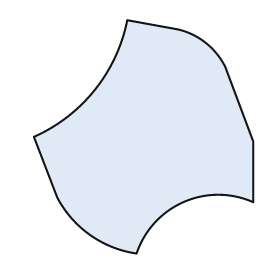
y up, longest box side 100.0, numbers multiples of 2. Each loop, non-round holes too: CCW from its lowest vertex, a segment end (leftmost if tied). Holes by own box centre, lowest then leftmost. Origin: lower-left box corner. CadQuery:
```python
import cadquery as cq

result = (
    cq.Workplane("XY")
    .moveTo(44.0, 0.0)
    .threePointArc((64.0, 22.0), (94.0, 22.0))
    .lineTo(94.0, 48.0)
    .lineTo(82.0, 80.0)
    .threePointArc((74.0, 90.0), (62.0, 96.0))
    .lineTo(40.0, 100.0)
    .threePointArc((26.0, 70.0), (0.0, 50.0))
    .lineTo(10.0, 24.0)
    .threePointArc((24.0, 8.0), (44.0, 0.0))
    .close()
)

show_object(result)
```